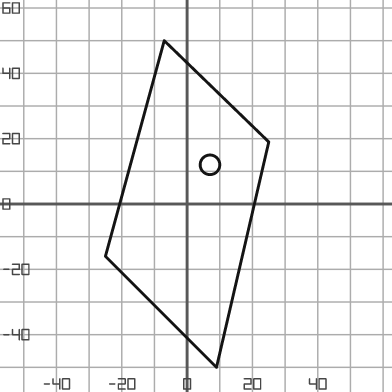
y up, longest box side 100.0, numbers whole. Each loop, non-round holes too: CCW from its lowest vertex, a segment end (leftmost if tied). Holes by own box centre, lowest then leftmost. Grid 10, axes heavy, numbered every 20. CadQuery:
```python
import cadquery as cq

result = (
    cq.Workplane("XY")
    .moveTo(9.0, -50.0)
    .lineTo(25.0, 19.0)
    .lineTo(-7.0, 50.0)
    .lineTo(-25.0, -16.0)
    .close()
    .moveTo(7.0, 12.0)
    .circle(3.0)
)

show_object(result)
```